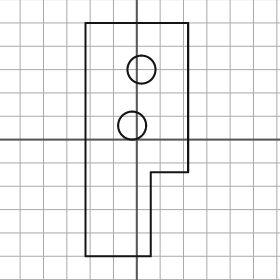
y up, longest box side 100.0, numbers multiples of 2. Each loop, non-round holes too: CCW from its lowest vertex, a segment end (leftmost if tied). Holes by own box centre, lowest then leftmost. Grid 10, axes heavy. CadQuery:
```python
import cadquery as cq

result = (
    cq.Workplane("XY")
    .moveTo(-22.0, -50.0)
    .lineTo(6.0, -50.0)
    .lineTo(6.0, -14.0)
    .lineTo(22.0, -14.0)
    .lineTo(22.0, 50.0)
    .lineTo(-22.0, 50.0)
    .close()
    .moveTo(-2.0, 6.0)
    .circle(6.0)
    .moveTo(2.0, 30.0)
    .circle(6.0)
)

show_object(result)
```